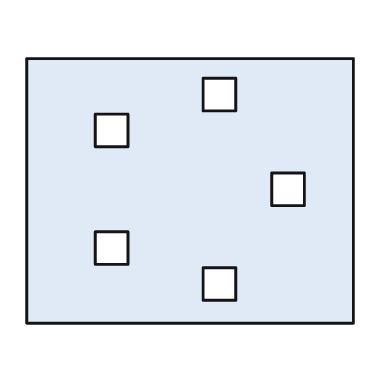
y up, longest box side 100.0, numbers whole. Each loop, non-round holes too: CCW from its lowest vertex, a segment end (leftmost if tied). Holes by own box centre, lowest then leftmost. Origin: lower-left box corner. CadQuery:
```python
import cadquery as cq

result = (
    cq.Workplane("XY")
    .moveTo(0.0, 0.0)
    .lineTo(100.0, 0.0)
    .lineTo(100.0, 81.0)
    .lineTo(0.0, 81.0)
    .close()
    .moveTo(54.0, 7.0)
    .lineTo(64.0, 7.0)
    .lineTo(64.0, 17.0)
    .lineTo(54.0, 17.0)
    .close()
    .moveTo(21.0, 18.0)
    .lineTo(31.0, 18.0)
    .lineTo(31.0, 28.0)
    .lineTo(21.0, 28.0)
    .close()
    .moveTo(75.0, 36.0)
    .lineTo(85.0, 36.0)
    .lineTo(85.0, 46.0)
    .lineTo(75.0, 46.0)
    .close()
    .moveTo(21.0, 54.0)
    .lineTo(31.0, 54.0)
    .lineTo(31.0, 64.0)
    .lineTo(21.0, 64.0)
    .close()
    .moveTo(54.0, 65.0)
    .lineTo(64.0, 65.0)
    .lineTo(64.0, 75.0)
    .lineTo(54.0, 75.0)
    .close()
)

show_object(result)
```